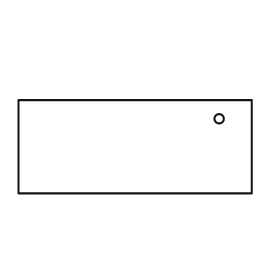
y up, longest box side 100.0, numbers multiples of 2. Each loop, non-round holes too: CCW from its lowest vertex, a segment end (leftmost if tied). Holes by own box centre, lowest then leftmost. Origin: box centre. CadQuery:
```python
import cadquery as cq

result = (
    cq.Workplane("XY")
    .moveTo(-50.0, -20.0)
    .lineTo(50.0, -20.0)
    .lineTo(50.0, 20.0)
    .lineTo(-50.0, 20.0)
    .close()
    .moveTo(36.0, 12.0)
    .circle(2.0)
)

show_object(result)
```